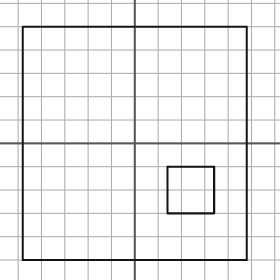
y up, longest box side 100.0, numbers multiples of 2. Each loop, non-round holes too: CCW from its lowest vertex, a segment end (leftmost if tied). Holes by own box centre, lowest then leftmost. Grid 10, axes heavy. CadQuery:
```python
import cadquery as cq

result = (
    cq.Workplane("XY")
    .moveTo(-48.0, -50.0)
    .lineTo(48.0, -50.0)
    .lineTo(48.0, 50.0)
    .lineTo(-48.0, 50.0)
    .close()
    .moveTo(14.0, -30.0)
    .lineTo(34.0, -30.0)
    .lineTo(34.0, -10.0)
    .lineTo(14.0, -10.0)
    .close()
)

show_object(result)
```